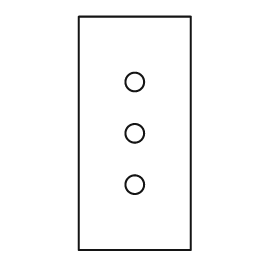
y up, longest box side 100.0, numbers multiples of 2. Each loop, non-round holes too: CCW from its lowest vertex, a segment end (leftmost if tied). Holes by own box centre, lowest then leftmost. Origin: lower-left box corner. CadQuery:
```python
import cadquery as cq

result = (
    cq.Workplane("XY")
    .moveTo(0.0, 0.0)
    .lineTo(48.0, 0.0)
    .lineTo(48.0, 100.0)
    .lineTo(0.0, 100.0)
    .close()
    .moveTo(24.0, 28.0)
    .circle(4.0)
    .moveTo(24.0, 50.0)
    .circle(4.0)
    .moveTo(24.0, 72.0)
    .circle(4.0)
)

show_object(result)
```